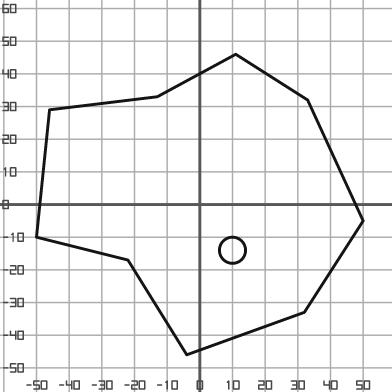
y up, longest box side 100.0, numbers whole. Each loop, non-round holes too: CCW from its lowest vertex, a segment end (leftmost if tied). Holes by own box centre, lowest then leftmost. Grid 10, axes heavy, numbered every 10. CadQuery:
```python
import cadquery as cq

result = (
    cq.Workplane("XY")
    .moveTo(-4.0, -46.0)
    .lineTo(32.0, -33.0)
    .lineTo(50.0, -5.0)
    .lineTo(33.0, 32.0)
    .lineTo(11.0, 46.0)
    .lineTo(-13.0, 33.0)
    .lineTo(-46.0, 29.0)
    .lineTo(-50.0, -10.0)
    .lineTo(-22.0, -17.0)
    .close()
    .moveTo(10.0, -14.0)
    .circle(4.0)
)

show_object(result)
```